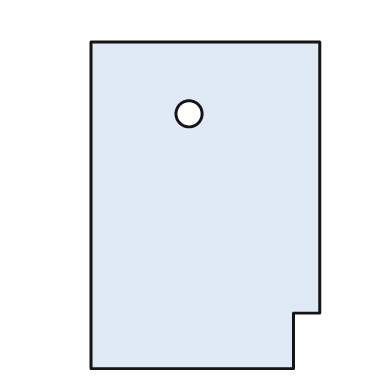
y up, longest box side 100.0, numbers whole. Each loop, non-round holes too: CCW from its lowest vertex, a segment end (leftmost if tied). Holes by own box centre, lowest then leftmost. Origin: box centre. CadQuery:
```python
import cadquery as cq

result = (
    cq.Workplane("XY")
    .moveTo(-35.0, -50.0)
    .lineTo(27.0, -50.0)
    .lineTo(27.0, -33.0)
    .lineTo(35.0, -33.0)
    .lineTo(35.0, 50.0)
    .lineTo(-35.0, 50.0)
    .close()
    .moveTo(-5.0, 28.0)
    .circle(4.0)
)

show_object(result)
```